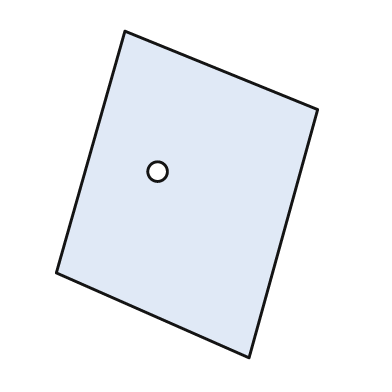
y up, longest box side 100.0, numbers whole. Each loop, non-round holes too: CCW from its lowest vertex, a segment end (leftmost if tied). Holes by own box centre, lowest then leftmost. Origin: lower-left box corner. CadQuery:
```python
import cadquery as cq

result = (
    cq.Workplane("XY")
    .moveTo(59.0, 0.0)
    .lineTo(80.0, 76.0)
    .lineTo(21.0, 100.0)
    .lineTo(0.0, 26.0)
    .close()
    .moveTo(31.0, 57.0)
    .circle(3.0)
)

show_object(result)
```